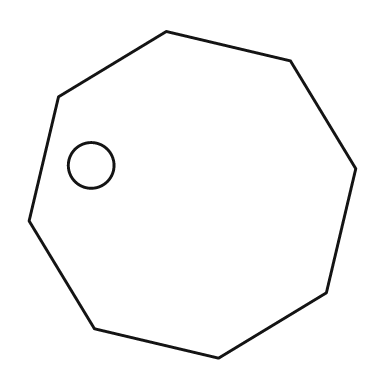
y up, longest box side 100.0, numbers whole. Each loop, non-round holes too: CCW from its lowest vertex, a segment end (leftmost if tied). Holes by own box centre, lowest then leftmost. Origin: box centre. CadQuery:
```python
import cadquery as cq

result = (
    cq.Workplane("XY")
    .moveTo(8.0, -50.0)
    .lineTo(41.0, -30.0)
    .lineTo(50.0, 8.0)
    .lineTo(30.0, 41.0)
    .lineTo(-8.0, 50.0)
    .lineTo(-41.0, 30.0)
    .lineTo(-50.0, -8.0)
    .lineTo(-30.0, -41.0)
    .close()
    .moveTo(-31.0, 9.0)
    .circle(7.0)
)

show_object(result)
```